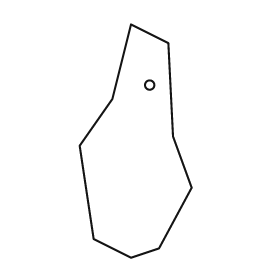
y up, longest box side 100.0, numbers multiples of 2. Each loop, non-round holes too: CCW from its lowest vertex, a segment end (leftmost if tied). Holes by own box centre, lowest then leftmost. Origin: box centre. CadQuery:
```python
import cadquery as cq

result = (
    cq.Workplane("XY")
    .moveTo(-2.0, -50.0)
    .lineTo(10.0, -46.0)
    .lineTo(24.0, -20.0)
    .lineTo(16.0, 2.0)
    .lineTo(14.0, 42.0)
    .lineTo(-2.0, 50.0)
    .lineTo(-10.0, 18.0)
    .lineTo(-24.0, -2.0)
    .lineTo(-18.0, -42.0)
    .close()
    .moveTo(6.0, 24.0)
    .circle(2.0)
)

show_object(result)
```